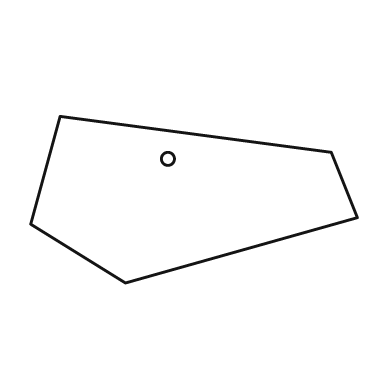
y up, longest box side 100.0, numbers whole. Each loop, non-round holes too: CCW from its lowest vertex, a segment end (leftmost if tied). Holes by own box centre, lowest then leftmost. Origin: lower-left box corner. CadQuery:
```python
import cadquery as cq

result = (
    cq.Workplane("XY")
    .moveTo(29.0, 0.0)
    .lineTo(100.0, 20.0)
    .lineTo(92.0, 40.0)
    .lineTo(9.0, 51.0)
    .lineTo(0.0, 18.0)
    .close()
    .moveTo(42.0, 38.0)
    .circle(2.0)
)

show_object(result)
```